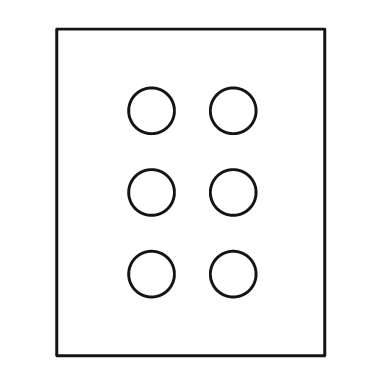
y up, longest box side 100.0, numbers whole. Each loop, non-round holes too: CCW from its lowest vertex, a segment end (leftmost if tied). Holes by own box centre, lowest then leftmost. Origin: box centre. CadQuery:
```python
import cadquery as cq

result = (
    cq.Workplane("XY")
    .moveTo(-41.0, -50.0)
    .lineTo(41.0, -50.0)
    .lineTo(41.0, 50.0)
    .lineTo(-41.0, 50.0)
    .close()
    .moveTo(-12.0, -25.0)
    .circle(7.0)
    .moveTo(13.0, -25.0)
    .circle(7.0)
    .moveTo(-12.0, 0.0)
    .circle(7.0)
    .moveTo(13.0, 0.0)
    .circle(7.0)
    .moveTo(-12.0, 25.0)
    .circle(7.0)
    .moveTo(13.0, 25.0)
    .circle(7.0)
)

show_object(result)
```